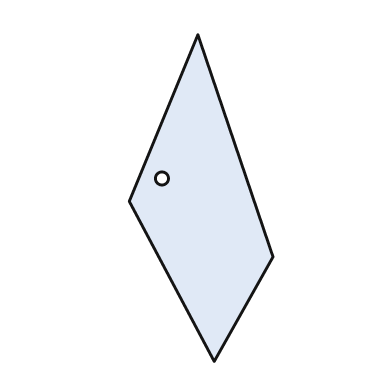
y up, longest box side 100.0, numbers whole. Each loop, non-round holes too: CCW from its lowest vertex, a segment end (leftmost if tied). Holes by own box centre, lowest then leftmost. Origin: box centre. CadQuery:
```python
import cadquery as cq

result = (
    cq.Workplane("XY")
    .moveTo(4.0, -50.0)
    .lineTo(22.0, -18.0)
    .lineTo(-1.0, 50.0)
    .lineTo(-22.0, -1.0)
    .close()
    .moveTo(-12.0, 6.0)
    .circle(2.0)
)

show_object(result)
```